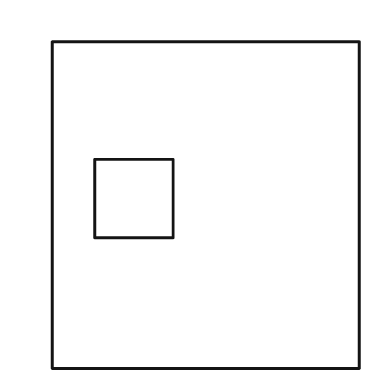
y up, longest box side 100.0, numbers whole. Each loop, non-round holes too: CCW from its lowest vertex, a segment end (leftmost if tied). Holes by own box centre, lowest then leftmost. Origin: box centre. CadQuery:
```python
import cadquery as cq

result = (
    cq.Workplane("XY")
    .moveTo(-47.0, -50.0)
    .lineTo(47.0, -50.0)
    .lineTo(47.0, 50.0)
    .lineTo(-47.0, 50.0)
    .close()
    .moveTo(-34.0, -10.0)
    .lineTo(-10.0, -10.0)
    .lineTo(-10.0, 14.0)
    .lineTo(-34.0, 14.0)
    .close()
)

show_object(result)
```